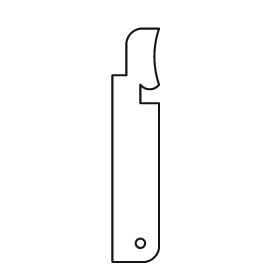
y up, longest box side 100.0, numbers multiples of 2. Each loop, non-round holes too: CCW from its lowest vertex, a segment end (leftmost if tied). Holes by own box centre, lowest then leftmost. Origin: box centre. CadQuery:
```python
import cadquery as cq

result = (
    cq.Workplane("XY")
    .moveTo(-10.0, -50.0)
    .lineTo(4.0, -50.0)
    .threePointArc((8.0, -48.0), (10.0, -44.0))
    .lineTo(10.0, 18.0)
    .lineTo(2.0, 18.0)
    .lineTo(2.0, 26.0)
    .threePointArc((6.0, 24.0), (10.0, 26.0))
    .threePointArc((8.0, 38.0), (10.0, 50.0))
    .lineTo(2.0, 50.0)
    .threePointArc((-2.0, 48.0), (-4.0, 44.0))
    .lineTo(-4.0, 30.0)
    .lineTo(-10.0, 30.0)
    .close()
    .moveTo(2.0, -42.0)
    .circle(2.0)
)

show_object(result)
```